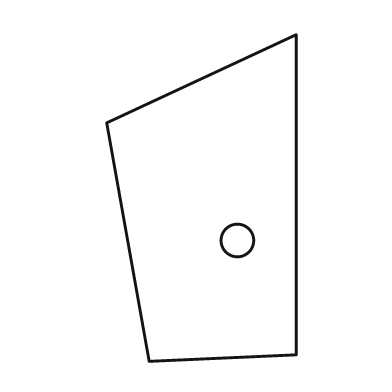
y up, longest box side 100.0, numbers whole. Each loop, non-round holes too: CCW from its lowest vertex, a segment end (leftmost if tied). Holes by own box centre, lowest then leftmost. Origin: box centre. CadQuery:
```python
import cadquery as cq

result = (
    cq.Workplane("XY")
    .moveTo(-16.0, -50.0)
    .lineTo(29.0, -48.0)
    .lineTo(29.0, 50.0)
    .lineTo(-29.0, 23.0)
    .close()
    .moveTo(11.0, -13.0)
    .circle(5.0)
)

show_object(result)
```